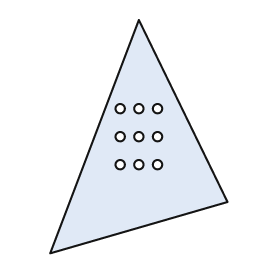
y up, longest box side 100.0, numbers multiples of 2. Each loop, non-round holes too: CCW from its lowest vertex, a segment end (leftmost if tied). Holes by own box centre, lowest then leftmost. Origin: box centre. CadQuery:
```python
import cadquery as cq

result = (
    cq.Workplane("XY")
    .moveTo(-38.0, -50.0)
    .lineTo(38.0, -28.0)
    .lineTo(0.0, 50.0)
    .close()
    .moveTo(-8.0, -12.0)
    .circle(2.0)
    .moveTo(0.0, -12.0)
    .circle(2.0)
    .moveTo(8.0, -12.0)
    .circle(2.0)
    .moveTo(-8.0, 0.0)
    .circle(2.0)
    .moveTo(0.0, 0.0)
    .circle(2.0)
    .moveTo(8.0, 0.0)
    .circle(2.0)
    .moveTo(-8.0, 12.0)
    .circle(2.0)
    .moveTo(0.0, 12.0)
    .circle(2.0)
    .moveTo(8.0, 12.0)
    .circle(2.0)
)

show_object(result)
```